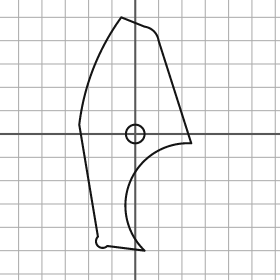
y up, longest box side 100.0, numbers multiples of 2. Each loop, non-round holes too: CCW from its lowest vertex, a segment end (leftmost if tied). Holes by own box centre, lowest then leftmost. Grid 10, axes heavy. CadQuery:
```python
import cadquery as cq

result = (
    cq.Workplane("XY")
    .moveTo(4.0, -50.0)
    .threePointArc((-2.0, -20.0), (24.0, -4.0))
    .lineTo(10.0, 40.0)
    .threePointArc((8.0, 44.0), (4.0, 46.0))
    .lineTo(-6.0, 50.0)
    .threePointArc((-18.0, 28.0), (-24.0, 4.0))
    .lineTo(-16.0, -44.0)
    .threePointArc((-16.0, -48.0), (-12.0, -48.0))
    .close()
    .moveTo(0.0, 0.0)
    .circle(4.0)
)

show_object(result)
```